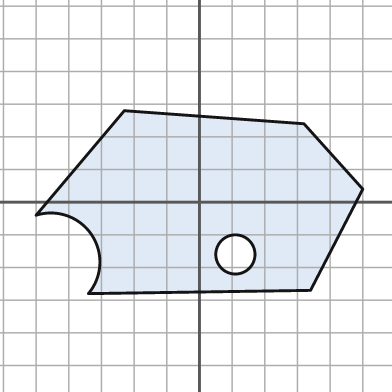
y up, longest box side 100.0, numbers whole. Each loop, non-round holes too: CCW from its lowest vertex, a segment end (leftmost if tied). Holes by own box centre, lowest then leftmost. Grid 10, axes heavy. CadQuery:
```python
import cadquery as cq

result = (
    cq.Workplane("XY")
    .moveTo(-34.0, -28.0)
    .lineTo(34.0, -27.0)
    .lineTo(50.0, 4.0)
    .lineTo(32.0, 24.0)
    .lineTo(-23.0, 28.0)
    .lineTo(-50.0, -4.0)
    .threePointArc((-33.0, -10.0), (-34.0, -28.0))
    .close()
    .moveTo(11.0, -16.0)
    .circle(6.0)
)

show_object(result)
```